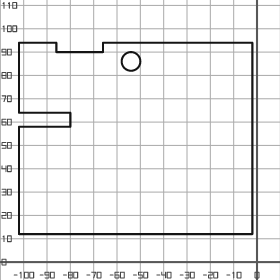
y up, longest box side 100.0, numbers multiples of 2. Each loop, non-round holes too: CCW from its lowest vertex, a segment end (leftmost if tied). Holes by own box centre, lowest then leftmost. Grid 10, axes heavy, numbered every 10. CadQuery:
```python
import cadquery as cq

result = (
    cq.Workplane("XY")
    .moveTo(-102.0, 12.0)
    .lineTo(-2.0, 12.0)
    .lineTo(-2.0, 94.0)
    .lineTo(-66.0, 94.0)
    .lineTo(-66.0, 90.0)
    .lineTo(-86.0, 90.0)
    .lineTo(-86.0, 94.0)
    .lineTo(-102.0, 94.0)
    .lineTo(-102.0, 64.0)
    .lineTo(-80.0, 64.0)
    .lineTo(-80.0, 58.0)
    .lineTo(-102.0, 58.0)
    .close()
    .moveTo(-54.0, 86.0)
    .circle(4.0)
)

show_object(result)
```